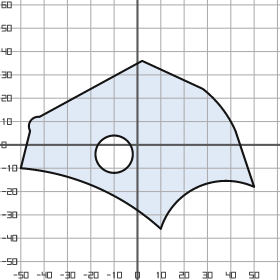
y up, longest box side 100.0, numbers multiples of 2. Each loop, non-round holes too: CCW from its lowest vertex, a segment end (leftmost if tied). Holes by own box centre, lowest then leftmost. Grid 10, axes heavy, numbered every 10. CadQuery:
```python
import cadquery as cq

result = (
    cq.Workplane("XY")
    .moveTo(10.0, -36.0)
    .threePointArc((26.0, -18.0), (50.0, -18.0))
    .lineTo(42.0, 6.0)
    .threePointArc((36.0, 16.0), (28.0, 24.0))
    .lineTo(2.0, 36.0)
    .lineTo(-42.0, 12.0)
    .threePointArc((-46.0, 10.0), (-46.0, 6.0))
    .lineTo(-50.0, -10.0)
    .threePointArc((-18.0, -18.0), (10.0, -36.0))
    .close()
    .moveTo(-10.0, -4.0)
    .circle(8.0)
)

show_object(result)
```